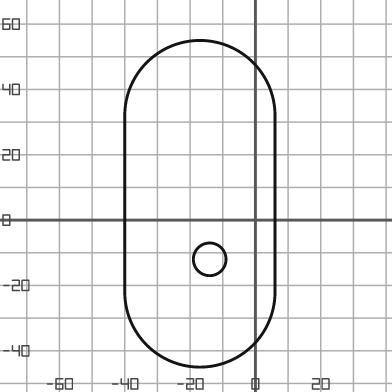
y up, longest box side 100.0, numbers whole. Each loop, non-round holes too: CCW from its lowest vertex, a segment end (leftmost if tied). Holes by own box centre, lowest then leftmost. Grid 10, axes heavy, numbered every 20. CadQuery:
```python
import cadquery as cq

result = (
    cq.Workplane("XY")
    .moveTo(-40.0, -22.0)
    .threePointArc((-17.0, -45.0), (6.0, -22.0))
    .lineTo(6.0, 32.0)
    .threePointArc((-17.0, 55.0), (-40.0, 32.0))
    .close()
    .moveTo(-14.0, -12.0)
    .circle(5.0)
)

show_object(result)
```